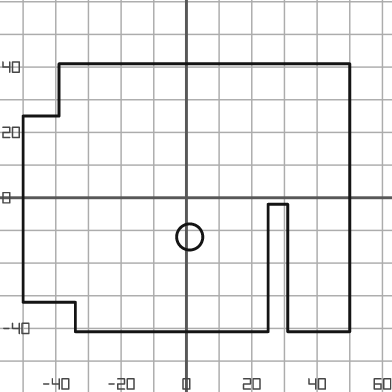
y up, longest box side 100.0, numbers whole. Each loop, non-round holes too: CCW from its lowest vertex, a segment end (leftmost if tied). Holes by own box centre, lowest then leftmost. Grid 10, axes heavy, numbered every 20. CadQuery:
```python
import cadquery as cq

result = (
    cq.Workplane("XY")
    .moveTo(-34.0, -41.0)
    .lineTo(25.0, -41.0)
    .lineTo(25.0, -2.0)
    .lineTo(31.0, -2.0)
    .lineTo(31.0, -41.0)
    .lineTo(50.0, -41.0)
    .lineTo(50.0, 41.0)
    .lineTo(-39.0, 41.0)
    .lineTo(-39.0, 25.0)
    .lineTo(-50.0, 25.0)
    .lineTo(-50.0, -32.0)
    .lineTo(-34.0, -32.0)
    .close()
    .moveTo(1.0, -12.0)
    .circle(4.0)
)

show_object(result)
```